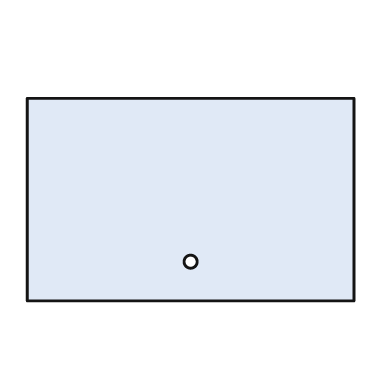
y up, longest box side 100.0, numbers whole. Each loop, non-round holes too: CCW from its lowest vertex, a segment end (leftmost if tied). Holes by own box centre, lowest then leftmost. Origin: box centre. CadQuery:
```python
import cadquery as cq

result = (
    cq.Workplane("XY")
    .moveTo(-50.0, -31.0)
    .lineTo(50.0, -31.0)
    .lineTo(50.0, 31.0)
    .lineTo(-50.0, 31.0)
    .close()
    .moveTo(0.0, -19.0)
    .circle(2.0)
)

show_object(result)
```